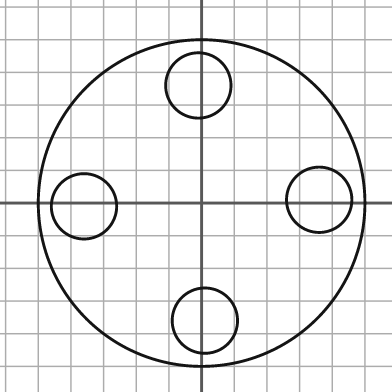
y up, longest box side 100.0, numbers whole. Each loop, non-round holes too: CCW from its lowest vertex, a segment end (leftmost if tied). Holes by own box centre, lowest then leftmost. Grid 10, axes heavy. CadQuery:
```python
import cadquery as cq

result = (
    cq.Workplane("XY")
    .moveTo(0.0, 0.0)
    .circle(50.0)
    .moveTo(1.0, -36.0)
    .circle(10.0)
    .moveTo(-36.0, -1.0)
    .circle(10.0)
    .moveTo(36.0, 1.0)
    .circle(10.0)
    .moveTo(-1.0, 36.0)
    .circle(10.0)
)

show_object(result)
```